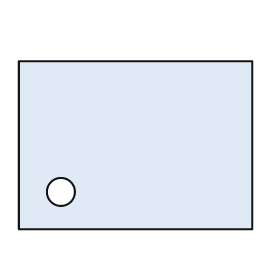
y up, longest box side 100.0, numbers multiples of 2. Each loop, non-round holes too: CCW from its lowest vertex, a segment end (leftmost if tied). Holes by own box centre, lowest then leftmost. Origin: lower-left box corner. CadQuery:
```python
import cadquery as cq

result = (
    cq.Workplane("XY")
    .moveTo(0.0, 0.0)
    .lineTo(100.0, 0.0)
    .lineTo(100.0, 72.0)
    .lineTo(0.0, 72.0)
    .close()
    .moveTo(18.0, 16.0)
    .circle(6.0)
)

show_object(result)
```